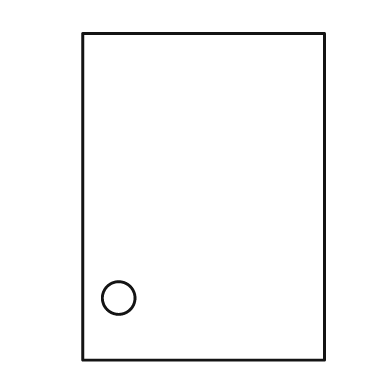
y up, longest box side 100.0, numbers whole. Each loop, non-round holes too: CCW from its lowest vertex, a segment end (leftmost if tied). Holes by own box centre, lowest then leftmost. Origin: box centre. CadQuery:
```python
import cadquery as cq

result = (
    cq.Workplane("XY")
    .moveTo(-37.0, -50.0)
    .lineTo(37.0, -50.0)
    .lineTo(37.0, 50.0)
    .lineTo(-37.0, 50.0)
    .close()
    .moveTo(-26.0, -31.0)
    .circle(5.0)
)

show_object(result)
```